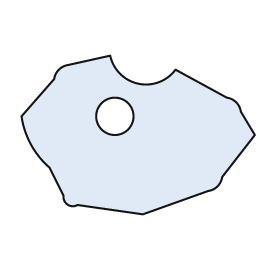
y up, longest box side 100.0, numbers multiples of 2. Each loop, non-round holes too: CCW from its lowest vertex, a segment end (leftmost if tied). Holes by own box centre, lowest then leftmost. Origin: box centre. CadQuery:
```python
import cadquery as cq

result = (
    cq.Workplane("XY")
    .moveTo(2.0, -34.0)
    .lineTo(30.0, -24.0)
    .threePointArc((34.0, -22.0), (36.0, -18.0))
    .lineTo(50.0, 0.0)
    .lineTo(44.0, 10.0)
    .threePointArc((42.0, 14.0), (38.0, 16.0))
    .lineTo(16.0, 28.0)
    .threePointArc((0.0, 22.0), (-12.0, 34.0))
    .lineTo(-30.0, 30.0)
    .threePointArc((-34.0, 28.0), (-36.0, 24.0))
    .lineTo(-50.0, 8.0)
    .threePointArc((-46.0, -4.0), (-38.0, -14.0))
    .lineTo(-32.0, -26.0)
    .threePointArc((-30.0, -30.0), (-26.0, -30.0))
    .close()
    .moveTo(-10.0, 8.0)
    .circle(8.0)
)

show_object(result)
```